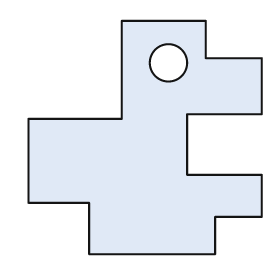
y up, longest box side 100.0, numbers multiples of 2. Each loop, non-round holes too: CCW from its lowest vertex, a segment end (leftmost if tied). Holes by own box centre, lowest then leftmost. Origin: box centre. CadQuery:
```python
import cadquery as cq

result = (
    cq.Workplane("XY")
    .moveTo(-24.0, -50.0)
    .lineTo(30.0, -50.0)
    .lineTo(30.0, -34.0)
    .lineTo(50.0, -34.0)
    .lineTo(50.0, -16.0)
    .lineTo(18.0, -16.0)
    .lineTo(18.0, 10.0)
    .lineTo(50.0, 10.0)
    .lineTo(50.0, 34.0)
    .lineTo(26.0, 34.0)
    .lineTo(26.0, 50.0)
    .lineTo(-10.0, 50.0)
    .lineTo(-10.0, 8.0)
    .lineTo(-50.0, 8.0)
    .lineTo(-50.0, -28.0)
    .lineTo(-24.0, -28.0)
    .close()
    .moveTo(10.0, 32.0)
    .circle(8.0)
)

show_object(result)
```